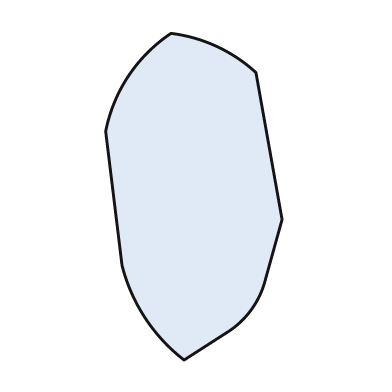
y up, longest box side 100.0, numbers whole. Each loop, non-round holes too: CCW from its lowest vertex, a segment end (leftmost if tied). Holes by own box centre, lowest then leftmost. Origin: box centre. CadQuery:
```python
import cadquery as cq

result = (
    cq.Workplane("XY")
    .moveTo(-3.0, -50.0)
    .lineTo(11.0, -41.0)
    .threePointArc((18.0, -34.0), (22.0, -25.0))
    .lineTo(27.0, -7.0)
    .lineTo(19.0, 38.0)
    .threePointArc((7.0, 46.0), (-7.0, 50.0))
    .threePointArc((-20.0, 37.0), (-27.0, 20.0))
    .lineTo(-22.0, -21.0)
    .threePointArc((-15.0, -37.0), (-3.0, -50.0))
    .close()
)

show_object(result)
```